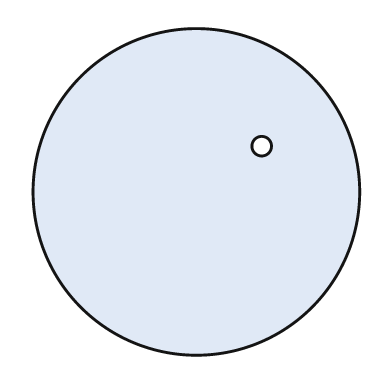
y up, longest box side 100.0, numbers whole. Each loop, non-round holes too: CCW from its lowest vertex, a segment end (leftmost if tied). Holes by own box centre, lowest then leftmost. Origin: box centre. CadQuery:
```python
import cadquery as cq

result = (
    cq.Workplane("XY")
    .moveTo(0.0, 0.0)
    .circle(50.0)
    .moveTo(20.0, 14.0)
    .circle(3.0)
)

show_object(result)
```